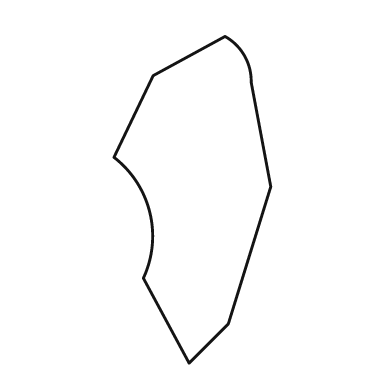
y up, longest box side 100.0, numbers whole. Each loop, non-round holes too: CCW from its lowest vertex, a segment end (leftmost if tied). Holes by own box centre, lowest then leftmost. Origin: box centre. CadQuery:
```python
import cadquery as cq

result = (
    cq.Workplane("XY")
    .moveTo(-1.0, -50.0)
    .lineTo(11.0, -38.0)
    .lineTo(24.0, 4.0)
    .lineTo(18.0, 36.0)
    .threePointArc((16.0, 44.0), (10.0, 50.0))
    .lineTo(-12.0, 38.0)
    .lineTo(-24.0, 13.0)
    .threePointArc((-13.0, -4.0), (-15.0, -24.0))
    .close()
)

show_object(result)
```